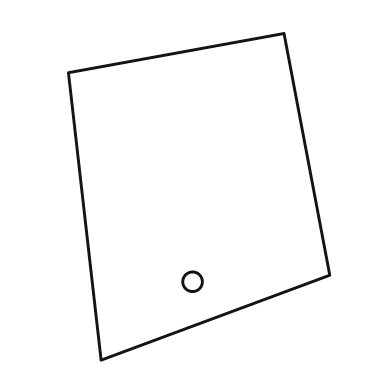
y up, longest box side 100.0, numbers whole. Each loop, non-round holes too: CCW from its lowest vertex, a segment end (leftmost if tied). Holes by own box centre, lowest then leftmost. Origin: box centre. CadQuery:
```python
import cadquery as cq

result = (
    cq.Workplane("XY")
    .moveTo(-30.0, -50.0)
    .lineTo(40.0, -24.0)
    .lineTo(26.0, 50.0)
    .lineTo(-40.0, 38.0)
    .close()
    .moveTo(-2.0, -26.0)
    .circle(3.0)
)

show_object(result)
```